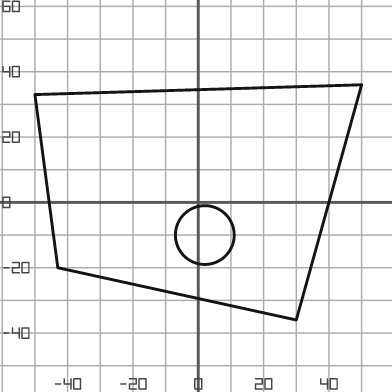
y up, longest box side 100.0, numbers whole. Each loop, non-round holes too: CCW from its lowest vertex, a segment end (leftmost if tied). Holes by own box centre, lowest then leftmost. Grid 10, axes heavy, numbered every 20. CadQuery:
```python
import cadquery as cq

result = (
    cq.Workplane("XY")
    .moveTo(30.0, -36.0)
    .lineTo(50.0, 36.0)
    .lineTo(-50.0, 33.0)
    .lineTo(-43.0, -20.0)
    .close()
    .moveTo(2.0, -10.0)
    .circle(9.0)
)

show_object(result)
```